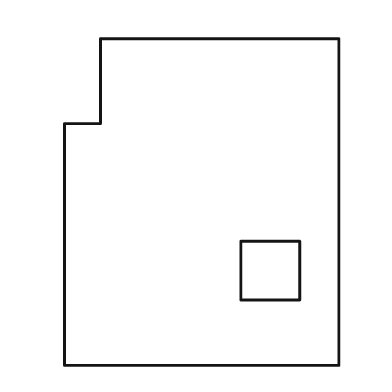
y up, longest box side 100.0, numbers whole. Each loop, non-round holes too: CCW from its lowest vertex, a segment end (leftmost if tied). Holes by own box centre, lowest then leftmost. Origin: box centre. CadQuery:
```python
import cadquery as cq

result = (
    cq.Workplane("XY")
    .moveTo(-42.0, -50.0)
    .lineTo(42.0, -50.0)
    .lineTo(42.0, 50.0)
    .lineTo(-31.0, 50.0)
    .lineTo(-31.0, 24.0)
    .lineTo(-42.0, 24.0)
    .close()
    .moveTo(12.0, -30.0)
    .lineTo(30.0, -30.0)
    .lineTo(30.0, -12.0)
    .lineTo(12.0, -12.0)
    .close()
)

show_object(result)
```